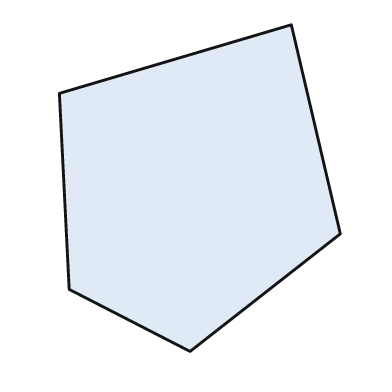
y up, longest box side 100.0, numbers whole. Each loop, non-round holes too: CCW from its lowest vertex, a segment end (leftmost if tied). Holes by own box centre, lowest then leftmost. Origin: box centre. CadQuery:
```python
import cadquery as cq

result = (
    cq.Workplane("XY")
    .moveTo(-3.0, -50.0)
    .lineTo(43.0, -14.0)
    .lineTo(28.0, 50.0)
    .lineTo(-43.0, 29.0)
    .lineTo(-40.0, -31.0)
    .close()
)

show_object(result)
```